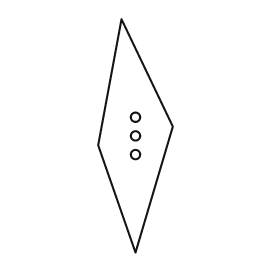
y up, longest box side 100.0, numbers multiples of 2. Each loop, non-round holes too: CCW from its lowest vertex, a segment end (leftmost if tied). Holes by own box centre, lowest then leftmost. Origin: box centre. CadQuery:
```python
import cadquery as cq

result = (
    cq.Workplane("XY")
    .moveTo(0.0, -50.0)
    .lineTo(16.0, 4.0)
    .lineTo(-6.0, 50.0)
    .lineTo(-16.0, -4.0)
    .close()
    .moveTo(0.0, -8.0)
    .circle(2.0)
    .moveTo(0.0, 0.0)
    .circle(2.0)
    .moveTo(0.0, 8.0)
    .circle(2.0)
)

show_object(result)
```